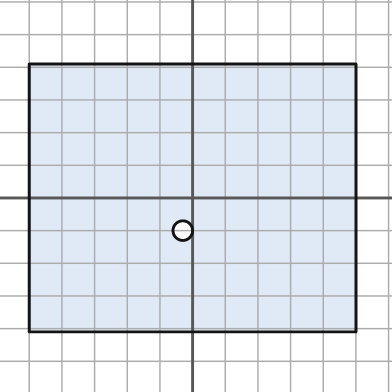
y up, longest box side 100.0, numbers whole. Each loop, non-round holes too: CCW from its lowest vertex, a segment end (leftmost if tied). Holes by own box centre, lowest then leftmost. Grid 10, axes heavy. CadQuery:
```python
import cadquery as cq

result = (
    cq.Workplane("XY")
    .moveTo(-50.0, -41.0)
    .lineTo(50.0, -41.0)
    .lineTo(50.0, 41.0)
    .lineTo(-50.0, 41.0)
    .close()
    .moveTo(-3.0, -10.0)
    .circle(3.0)
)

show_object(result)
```